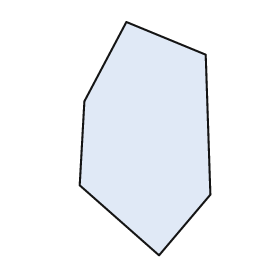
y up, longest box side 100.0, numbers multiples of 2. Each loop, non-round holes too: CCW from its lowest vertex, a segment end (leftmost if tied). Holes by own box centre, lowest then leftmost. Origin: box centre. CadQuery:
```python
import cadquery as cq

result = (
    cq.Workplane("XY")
    .moveTo(6.0, -50.0)
    .lineTo(28.0, -24.0)
    .lineTo(26.0, 36.0)
    .lineTo(-8.0, 50.0)
    .lineTo(-26.0, 16.0)
    .lineTo(-28.0, -20.0)
    .close()
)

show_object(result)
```